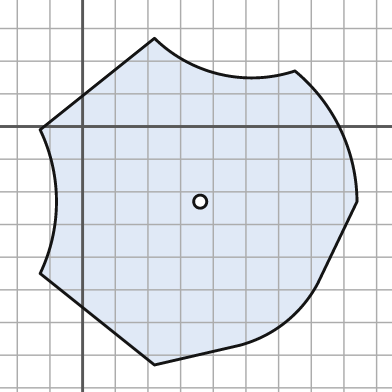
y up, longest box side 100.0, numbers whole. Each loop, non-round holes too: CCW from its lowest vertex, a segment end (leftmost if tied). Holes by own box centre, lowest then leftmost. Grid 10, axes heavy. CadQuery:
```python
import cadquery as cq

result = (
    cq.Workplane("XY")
    .moveTo(22.0, -73.0)
    .lineTo(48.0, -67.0)
    .threePointArc((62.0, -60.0), (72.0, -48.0))
    .lineTo(84.0, -23.0)
    .threePointArc((79.0, -1.0), (65.0, 17.0))
    .threePointArc((42.0, 16.0), (22.0, 27.0))
    .lineTo(-13.0, -1.0)
    .threePointArc((-8.0, -23.0), (-13.0, -45.0))
    .close()
    .moveTo(36.0, -23.0)
    .circle(2.0)
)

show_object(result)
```